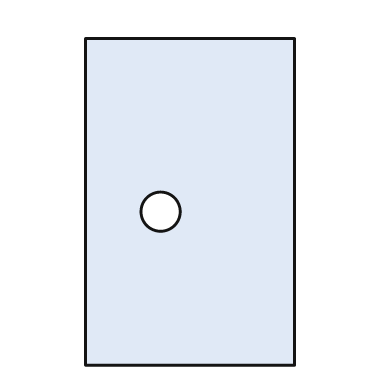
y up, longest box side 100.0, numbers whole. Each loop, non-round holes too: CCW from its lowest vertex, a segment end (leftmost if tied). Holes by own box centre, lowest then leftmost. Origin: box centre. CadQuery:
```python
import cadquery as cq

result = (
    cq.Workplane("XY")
    .moveTo(-32.0, -50.0)
    .lineTo(32.0, -50.0)
    .lineTo(32.0, 50.0)
    .lineTo(-32.0, 50.0)
    .close()
    .moveTo(-9.0, -3.0)
    .circle(6.0)
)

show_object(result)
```